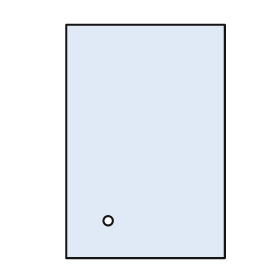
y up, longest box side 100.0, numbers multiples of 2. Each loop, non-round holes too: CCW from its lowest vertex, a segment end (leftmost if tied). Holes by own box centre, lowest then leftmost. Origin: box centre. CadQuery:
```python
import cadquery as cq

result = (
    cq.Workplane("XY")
    .moveTo(-34.0, -50.0)
    .lineTo(34.0, -50.0)
    .lineTo(34.0, 50.0)
    .lineTo(-34.0, 50.0)
    .close()
    .moveTo(-16.0, -34.0)
    .circle(2.0)
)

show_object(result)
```